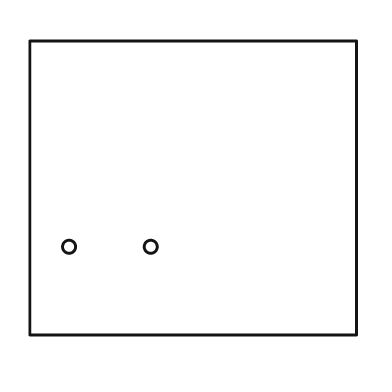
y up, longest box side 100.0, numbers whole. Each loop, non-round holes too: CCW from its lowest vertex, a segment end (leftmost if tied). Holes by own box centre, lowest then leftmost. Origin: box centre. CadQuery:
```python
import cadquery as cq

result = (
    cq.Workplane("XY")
    .moveTo(-50.0, -45.0)
    .lineTo(50.0, -45.0)
    .lineTo(50.0, 45.0)
    .lineTo(-50.0, 45.0)
    .close()
    .moveTo(-38.0, -18.0)
    .circle(2.0)
    .moveTo(-13.0, -18.0)
    .circle(2.0)
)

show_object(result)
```